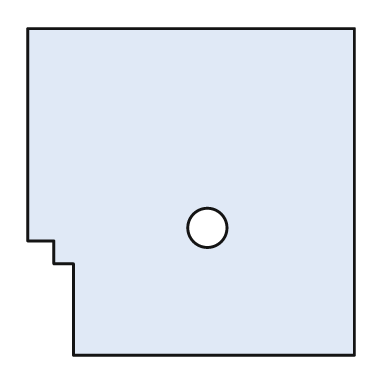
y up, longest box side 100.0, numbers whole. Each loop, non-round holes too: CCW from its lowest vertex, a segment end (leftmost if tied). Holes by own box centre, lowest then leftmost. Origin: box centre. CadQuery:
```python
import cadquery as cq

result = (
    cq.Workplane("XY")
    .moveTo(-36.0, -50.0)
    .lineTo(50.0, -50.0)
    .lineTo(50.0, 50.0)
    .lineTo(-50.0, 50.0)
    .lineTo(-50.0, -15.0)
    .lineTo(-42.0, -15.0)
    .lineTo(-42.0, -22.0)
    .lineTo(-36.0, -22.0)
    .close()
    .moveTo(5.0, -11.0)
    .circle(6.0)
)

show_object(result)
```